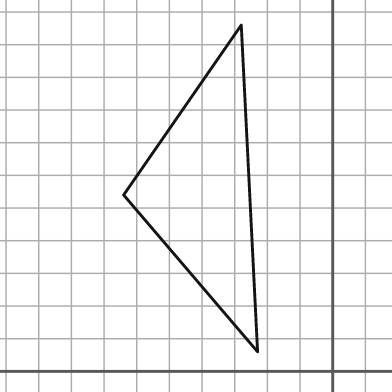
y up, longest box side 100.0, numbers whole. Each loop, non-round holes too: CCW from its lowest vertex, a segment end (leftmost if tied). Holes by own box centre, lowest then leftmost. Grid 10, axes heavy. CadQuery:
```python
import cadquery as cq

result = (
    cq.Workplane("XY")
    .moveTo(-23.0, 6.0)
    .lineTo(-28.0, 106.0)
    .lineTo(-64.0, 54.0)
    .close()
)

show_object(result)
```